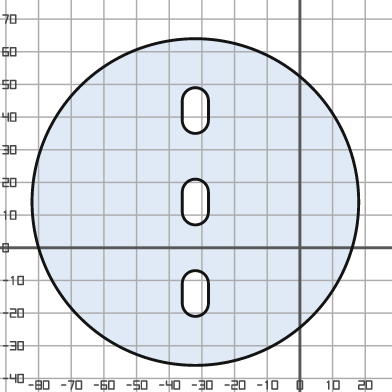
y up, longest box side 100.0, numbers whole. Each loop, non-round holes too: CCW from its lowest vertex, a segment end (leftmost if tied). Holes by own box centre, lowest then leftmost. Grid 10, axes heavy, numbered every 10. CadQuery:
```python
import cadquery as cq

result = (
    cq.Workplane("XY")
    .moveTo(-32.0, 14.0)
    .circle(50.0)
    .moveTo(-36.0, -17.0)
    .threePointArc((-32.0, -21.0), (-28.0, -17.0))
    .lineTo(-28.0, -11.0)
    .threePointArc((-32.0, -7.0), (-36.0, -11.0))
    .close()
    .moveTo(-36.0, 11.0)
    .threePointArc((-32.0, 7.0), (-28.0, 11.0))
    .lineTo(-28.0, 17.0)
    .threePointArc((-32.0, 21.0), (-36.0, 17.0))
    .close()
    .moveTo(-36.0, 39.0)
    .threePointArc((-32.0, 35.0), (-28.0, 39.0))
    .lineTo(-28.0, 45.0)
    .threePointArc((-32.0, 49.0), (-36.0, 45.0))
    .close()
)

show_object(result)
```